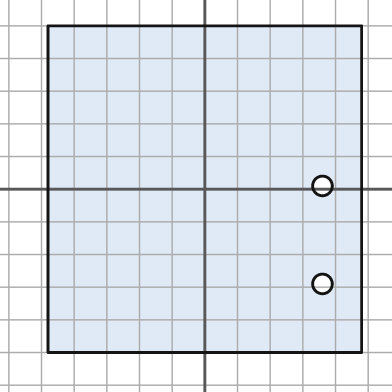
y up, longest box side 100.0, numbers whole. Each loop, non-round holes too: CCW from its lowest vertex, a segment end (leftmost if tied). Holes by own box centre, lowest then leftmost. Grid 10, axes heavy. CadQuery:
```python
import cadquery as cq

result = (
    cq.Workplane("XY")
    .moveTo(-48.0, -50.0)
    .lineTo(48.0, -50.0)
    .lineTo(48.0, 50.0)
    .lineTo(-48.0, 50.0)
    .close()
    .moveTo(36.0, -29.0)
    .circle(3.0)
    .moveTo(36.0, 1.0)
    .circle(3.0)
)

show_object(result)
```